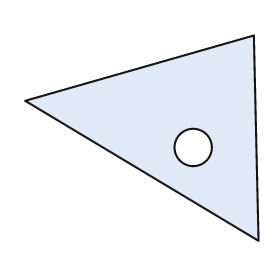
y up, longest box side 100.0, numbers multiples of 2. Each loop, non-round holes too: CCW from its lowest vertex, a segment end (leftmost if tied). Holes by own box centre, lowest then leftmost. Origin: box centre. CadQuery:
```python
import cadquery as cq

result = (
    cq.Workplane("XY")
    .moveTo(50.0, -44.0)
    .lineTo(48.0, 44.0)
    .lineTo(-50.0, 16.0)
    .close()
    .moveTo(22.0, -4.0)
    .circle(8.0)
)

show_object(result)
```